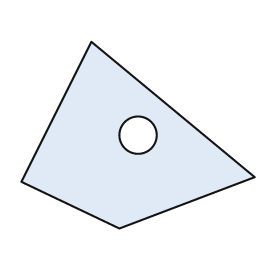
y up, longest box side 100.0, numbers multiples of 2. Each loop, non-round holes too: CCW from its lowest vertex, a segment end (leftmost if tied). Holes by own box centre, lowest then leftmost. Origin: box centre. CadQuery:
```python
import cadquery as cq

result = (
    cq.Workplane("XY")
    .moveTo(-8.0, -40.0)
    .lineTo(50.0, -18.0)
    .lineTo(-20.0, 40.0)
    .lineTo(-50.0, -20.0)
    .close()
    .moveTo(0.0, 0.0)
    .circle(8.0)
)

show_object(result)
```